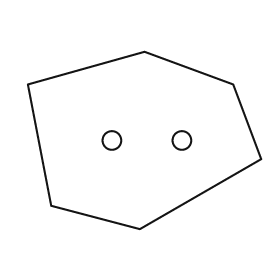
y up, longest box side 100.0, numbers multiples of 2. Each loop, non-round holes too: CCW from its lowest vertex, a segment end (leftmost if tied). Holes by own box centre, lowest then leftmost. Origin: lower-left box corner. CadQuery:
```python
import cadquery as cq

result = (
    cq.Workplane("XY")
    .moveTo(48.0, 0.0)
    .lineTo(100.0, 30.0)
    .lineTo(88.0, 62.0)
    .lineTo(50.0, 76.0)
    .lineTo(0.0, 62.0)
    .lineTo(10.0, 10.0)
    .close()
    .moveTo(36.0, 38.0)
    .circle(4.0)
    .moveTo(66.0, 38.0)
    .circle(4.0)
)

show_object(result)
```